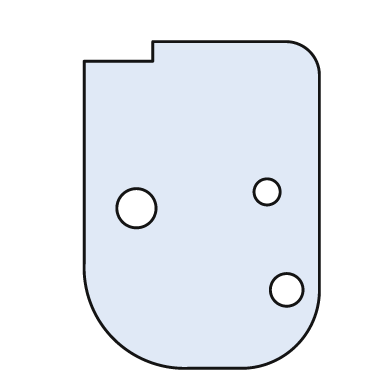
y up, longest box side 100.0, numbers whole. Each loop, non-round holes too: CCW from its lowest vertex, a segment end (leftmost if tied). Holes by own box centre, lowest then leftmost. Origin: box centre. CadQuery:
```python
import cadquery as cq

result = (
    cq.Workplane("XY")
    .moveTo(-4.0, -50.0)
    .lineTo(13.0, -50.0)
    .threePointArc((29.0, -43.0), (36.0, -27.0))
    .lineTo(36.0, 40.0)
    .threePointArc((33.0, 47.0), (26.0, 50.0))
    .lineTo(-15.0, 50.0)
    .lineTo(-15.0, 44.0)
    .lineTo(-36.0, 44.0)
    .lineTo(-36.0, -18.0)
    .threePointArc((-27.0, -41.0), (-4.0, -50.0))
    .close()
    .moveTo(26.0, -26.0)
    .circle(5.0)
    .moveTo(-20.0, -1.0)
    .circle(6.0)
    .moveTo(20.0, 4.0)
    .circle(4.0)
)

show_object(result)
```